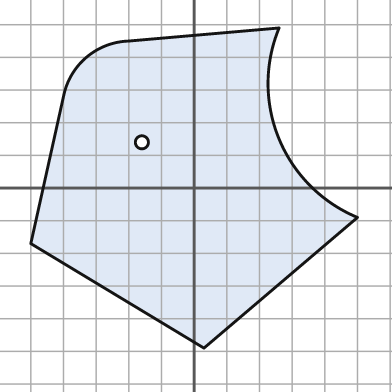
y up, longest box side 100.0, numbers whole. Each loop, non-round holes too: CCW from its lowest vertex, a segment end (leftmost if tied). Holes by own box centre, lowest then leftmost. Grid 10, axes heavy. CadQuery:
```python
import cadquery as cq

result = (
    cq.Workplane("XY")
    .moveTo(3.0, -49.0)
    .lineTo(50.0, -9.0)
    .threePointArc((26.0, 15.0), (26.0, 49.0))
    .lineTo(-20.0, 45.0)
    .threePointArc((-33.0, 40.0), (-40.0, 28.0))
    .lineTo(-50.0, -17.0)
    .close()
    .moveTo(-16.0, 14.0)
    .circle(2.0)
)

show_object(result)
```